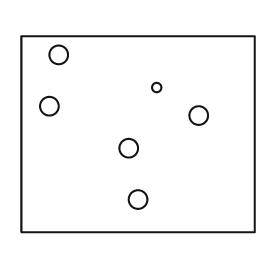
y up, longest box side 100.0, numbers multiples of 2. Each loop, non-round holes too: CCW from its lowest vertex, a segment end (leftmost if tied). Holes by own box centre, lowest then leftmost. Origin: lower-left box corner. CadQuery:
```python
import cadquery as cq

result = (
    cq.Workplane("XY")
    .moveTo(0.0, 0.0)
    .lineTo(100.0, 0.0)
    .lineTo(100.0, 84.0)
    .lineTo(0.0, 84.0)
    .close()
    .moveTo(50.0, 14.0)
    .circle(4.0)
    .moveTo(46.0, 36.0)
    .circle(4.0)
    .moveTo(76.0, 50.0)
    .circle(4.0)
    .moveTo(12.0, 54.0)
    .circle(4.0)
    .moveTo(58.0, 62.0)
    .circle(2.0)
    .moveTo(16.0, 76.0)
    .circle(4.0)
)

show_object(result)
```